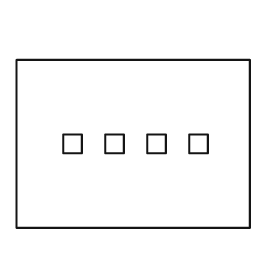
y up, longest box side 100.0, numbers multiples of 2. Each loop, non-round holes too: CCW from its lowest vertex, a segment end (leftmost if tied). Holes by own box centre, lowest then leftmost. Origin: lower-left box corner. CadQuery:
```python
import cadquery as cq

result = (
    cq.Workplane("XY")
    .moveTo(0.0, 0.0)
    .lineTo(100.0, 0.0)
    .lineTo(100.0, 72.0)
    .lineTo(0.0, 72.0)
    .close()
    .moveTo(20.0, 32.0)
    .lineTo(28.0, 32.0)
    .lineTo(28.0, 40.0)
    .lineTo(20.0, 40.0)
    .close()
    .moveTo(38.0, 32.0)
    .lineTo(46.0, 32.0)
    .lineTo(46.0, 40.0)
    .lineTo(38.0, 40.0)
    .close()
    .moveTo(56.0, 32.0)
    .lineTo(64.0, 32.0)
    .lineTo(64.0, 40.0)
    .lineTo(56.0, 40.0)
    .close()
    .moveTo(74.0, 32.0)
    .lineTo(82.0, 32.0)
    .lineTo(82.0, 40.0)
    .lineTo(74.0, 40.0)
    .close()
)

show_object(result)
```